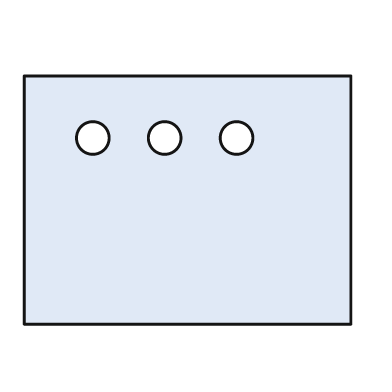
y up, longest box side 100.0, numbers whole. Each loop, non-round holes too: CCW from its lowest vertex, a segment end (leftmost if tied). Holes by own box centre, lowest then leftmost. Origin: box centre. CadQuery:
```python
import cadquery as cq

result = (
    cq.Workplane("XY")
    .moveTo(-50.0, -38.0)
    .lineTo(50.0, -38.0)
    .lineTo(50.0, 38.0)
    .lineTo(-50.0, 38.0)
    .close()
    .moveTo(-29.0, 19.0)
    .circle(5.0)
    .moveTo(-7.0, 19.0)
    .circle(5.0)
    .moveTo(15.0, 19.0)
    .circle(5.0)
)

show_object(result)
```